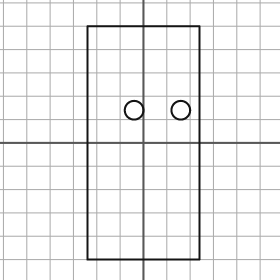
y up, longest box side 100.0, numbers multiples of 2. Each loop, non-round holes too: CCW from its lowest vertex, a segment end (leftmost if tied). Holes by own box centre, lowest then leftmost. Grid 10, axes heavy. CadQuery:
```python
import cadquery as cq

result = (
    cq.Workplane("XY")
    .moveTo(-24.0, -50.0)
    .lineTo(24.0, -50.0)
    .lineTo(24.0, 50.0)
    .lineTo(-24.0, 50.0)
    .close()
    .moveTo(-4.0, 14.0)
    .circle(4.0)
    .moveTo(16.0, 14.0)
    .circle(4.0)
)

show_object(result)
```